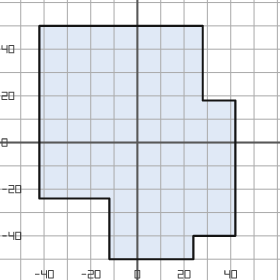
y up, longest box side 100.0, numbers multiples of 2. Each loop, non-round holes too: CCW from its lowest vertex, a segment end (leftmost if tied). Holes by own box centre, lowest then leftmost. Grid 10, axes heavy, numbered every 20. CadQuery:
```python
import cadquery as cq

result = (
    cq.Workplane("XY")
    .moveTo(-12.0, -50.0)
    .lineTo(24.0, -50.0)
    .lineTo(24.0, -40.0)
    .lineTo(42.0, -40.0)
    .lineTo(42.0, 18.0)
    .lineTo(28.0, 18.0)
    .lineTo(28.0, 50.0)
    .lineTo(-42.0, 50.0)
    .lineTo(-42.0, -24.0)
    .lineTo(-12.0, -24.0)
    .close()
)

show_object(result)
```